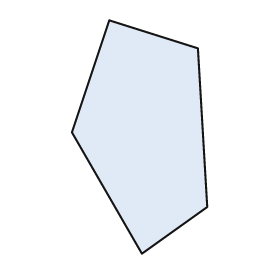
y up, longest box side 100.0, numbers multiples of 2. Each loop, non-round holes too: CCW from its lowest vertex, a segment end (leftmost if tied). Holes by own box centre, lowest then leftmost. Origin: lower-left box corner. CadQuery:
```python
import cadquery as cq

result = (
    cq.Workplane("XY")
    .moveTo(30.0, 0.0)
    .lineTo(58.0, 20.0)
    .lineTo(54.0, 88.0)
    .lineTo(16.0, 100.0)
    .lineTo(0.0, 52.0)
    .close()
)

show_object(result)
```